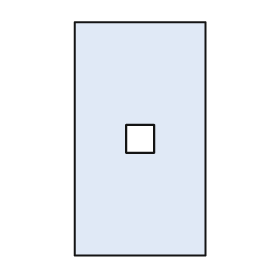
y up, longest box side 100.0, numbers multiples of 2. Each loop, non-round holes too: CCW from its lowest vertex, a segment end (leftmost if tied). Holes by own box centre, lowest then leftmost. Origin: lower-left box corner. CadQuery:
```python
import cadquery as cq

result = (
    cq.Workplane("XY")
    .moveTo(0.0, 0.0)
    .lineTo(56.0, 0.0)
    .lineTo(56.0, 100.0)
    .lineTo(0.0, 100.0)
    .close()
    .moveTo(22.0, 44.0)
    .lineTo(34.0, 44.0)
    .lineTo(34.0, 56.0)
    .lineTo(22.0, 56.0)
    .close()
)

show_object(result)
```